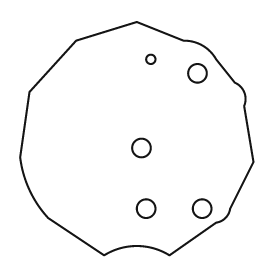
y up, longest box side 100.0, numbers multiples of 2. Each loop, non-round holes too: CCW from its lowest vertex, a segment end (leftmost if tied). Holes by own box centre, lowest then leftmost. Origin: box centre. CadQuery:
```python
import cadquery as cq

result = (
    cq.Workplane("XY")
    .moveTo(-14.0, -50.0)
    .threePointArc((0.0, -46.0), (14.0, -50.0))
    .lineTo(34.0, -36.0)
    .threePointArc((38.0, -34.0), (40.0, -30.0))
    .lineTo(50.0, -10.0)
    .lineTo(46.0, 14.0)
    .threePointArc((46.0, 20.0), (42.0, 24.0))
    .lineTo(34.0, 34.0)
    .threePointArc((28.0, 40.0), (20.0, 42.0))
    .lineTo(0.0, 50.0)
    .lineTo(-26.0, 42.0)
    .lineTo(-46.0, 20.0)
    .lineTo(-50.0, -8.0)
    .threePointArc((-46.0, -22.0), (-38.0, -34.0))
    .close()
    .moveTo(4.0, -30.0)
    .circle(4.0)
    .moveTo(28.0, -30.0)
    .circle(4.0)
    .moveTo(2.0, -4.0)
    .circle(4.0)
    .moveTo(26.0, 28.0)
    .circle(4.0)
    .moveTo(6.0, 34.0)
    .circle(2.0)
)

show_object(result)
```